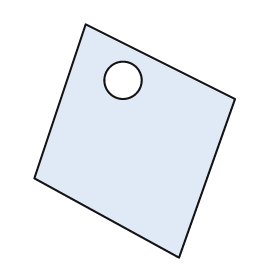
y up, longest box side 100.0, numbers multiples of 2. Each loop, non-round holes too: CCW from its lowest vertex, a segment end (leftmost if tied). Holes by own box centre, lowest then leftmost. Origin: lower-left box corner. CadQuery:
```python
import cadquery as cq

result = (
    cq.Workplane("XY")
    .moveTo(62.0, 0.0)
    .lineTo(86.0, 68.0)
    .lineTo(22.0, 100.0)
    .lineTo(0.0, 34.0)
    .close()
    .moveTo(38.0, 76.0)
    .circle(8.0)
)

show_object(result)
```